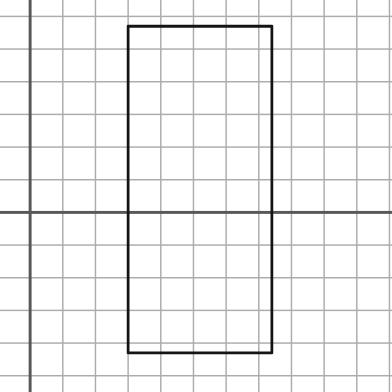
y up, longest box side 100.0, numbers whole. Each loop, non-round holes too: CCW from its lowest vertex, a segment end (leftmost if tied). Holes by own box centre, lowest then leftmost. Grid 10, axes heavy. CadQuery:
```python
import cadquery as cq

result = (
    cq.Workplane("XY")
    .moveTo(30.0, -43.0)
    .lineTo(74.0, -43.0)
    .lineTo(74.0, 57.0)
    .lineTo(30.0, 57.0)
    .close()
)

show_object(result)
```